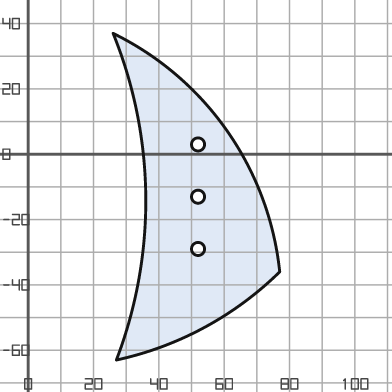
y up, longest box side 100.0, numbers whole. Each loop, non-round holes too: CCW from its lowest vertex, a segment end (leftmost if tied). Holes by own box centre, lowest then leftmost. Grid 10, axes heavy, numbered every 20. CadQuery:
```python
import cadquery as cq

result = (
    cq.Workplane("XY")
    .moveTo(27.0, -63.0)
    .threePointArc((54.0, -53.0), (77.0, -36.0))
    .threePointArc((61.0, 7.0), (26.0, 37.0))
    .threePointArc((36.0, -13.0), (27.0, -63.0))
    .close()
    .moveTo(52.0, -29.0)
    .circle(2.0)
    .moveTo(52.0, -13.0)
    .circle(2.0)
    .moveTo(52.0, 3.0)
    .circle(2.0)
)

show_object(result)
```